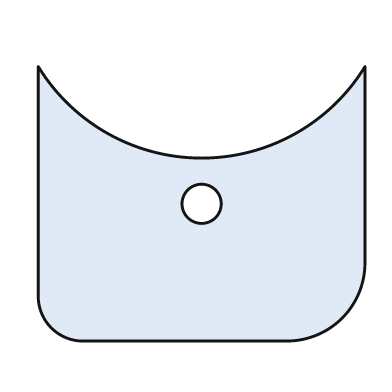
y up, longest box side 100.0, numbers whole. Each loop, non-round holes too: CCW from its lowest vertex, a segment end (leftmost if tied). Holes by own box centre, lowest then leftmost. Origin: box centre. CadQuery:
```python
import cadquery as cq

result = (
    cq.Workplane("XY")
    .moveTo(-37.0, -42.0)
    .lineTo(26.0, -42.0)
    .threePointArc((43.0, -35.0), (50.0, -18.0))
    .lineTo(50.0, 42.0)
    .threePointArc((0.0, 14.0), (-50.0, 42.0))
    .lineTo(-50.0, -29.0)
    .threePointArc((-46.0, -38.0), (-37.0, -42.0))
    .close()
    .moveTo(0.0, 0.0)
    .circle(6.0)
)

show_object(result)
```